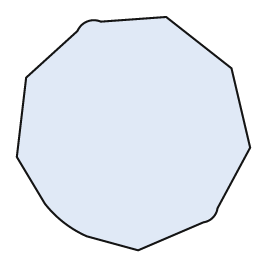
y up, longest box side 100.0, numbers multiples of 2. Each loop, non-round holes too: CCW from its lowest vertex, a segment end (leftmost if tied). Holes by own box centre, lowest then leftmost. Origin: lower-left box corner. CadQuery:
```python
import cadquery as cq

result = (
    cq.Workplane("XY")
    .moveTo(52.0, 0.0)
    .lineTo(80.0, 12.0)
    .threePointArc((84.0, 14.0), (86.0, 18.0))
    .lineTo(100.0, 44.0)
    .lineTo(92.0, 78.0)
    .lineTo(64.0, 100.0)
    .lineTo(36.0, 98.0)
    .threePointArc((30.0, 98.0), (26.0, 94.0))
    .lineTo(4.0, 74.0)
    .lineTo(0.0, 40.0)
    .lineTo(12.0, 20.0)
    .threePointArc((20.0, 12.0), (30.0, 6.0))
    .close()
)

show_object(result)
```